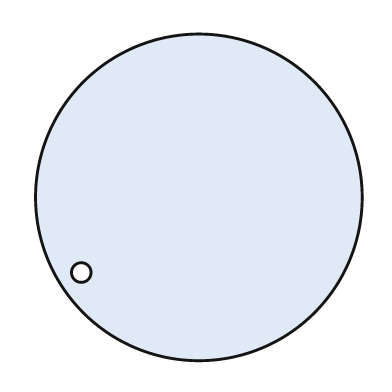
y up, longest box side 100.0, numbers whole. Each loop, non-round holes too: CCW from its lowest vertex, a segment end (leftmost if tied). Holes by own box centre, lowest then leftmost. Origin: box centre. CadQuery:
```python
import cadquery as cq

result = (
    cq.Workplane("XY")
    .moveTo(0.0, 0.0)
    .circle(50.0)
    .moveTo(-36.0, -23.0)
    .circle(3.0)
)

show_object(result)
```